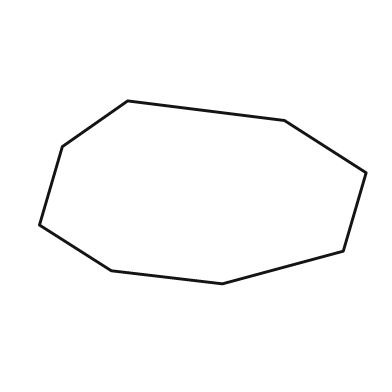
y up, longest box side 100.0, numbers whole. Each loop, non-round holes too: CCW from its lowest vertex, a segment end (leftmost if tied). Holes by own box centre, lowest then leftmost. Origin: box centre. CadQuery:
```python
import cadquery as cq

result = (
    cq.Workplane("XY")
    .moveTo(6.0, -28.0)
    .lineTo(43.0, -18.0)
    .lineTo(50.0, 6.0)
    .lineTo(25.0, 22.0)
    .lineTo(-23.0, 28.0)
    .lineTo(-43.0, 14.0)
    .lineTo(-50.0, -10.0)
    .lineTo(-28.0, -24.0)
    .close()
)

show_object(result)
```